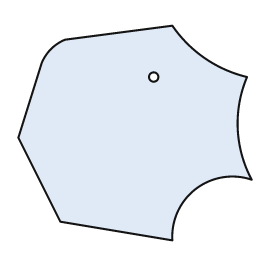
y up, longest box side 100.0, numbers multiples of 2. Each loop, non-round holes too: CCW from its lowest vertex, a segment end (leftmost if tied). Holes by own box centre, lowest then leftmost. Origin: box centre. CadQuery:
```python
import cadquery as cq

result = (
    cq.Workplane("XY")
    .moveTo(16.0, -46.0)
    .threePointArc((26.0, -24.0), (50.0, -20.0))
    .threePointArc((44.0, 2.0), (48.0, 24.0))
    .threePointArc((30.0, 32.0), (16.0, 46.0))
    .lineTo(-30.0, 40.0)
    .threePointArc((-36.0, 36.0), (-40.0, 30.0))
    .lineTo(-50.0, -2.0)
    .lineTo(-32.0, -38.0)
    .close()
    .moveTo(8.0, 24.0)
    .circle(2.0)
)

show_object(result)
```